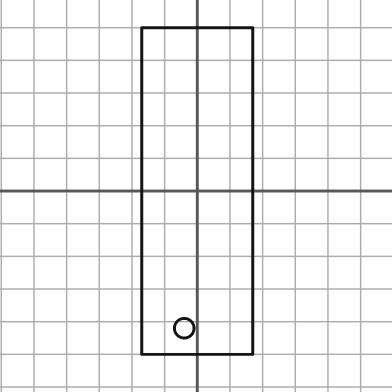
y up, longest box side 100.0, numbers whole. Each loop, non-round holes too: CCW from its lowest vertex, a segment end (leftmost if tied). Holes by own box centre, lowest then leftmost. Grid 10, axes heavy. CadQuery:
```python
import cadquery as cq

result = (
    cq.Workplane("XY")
    .moveTo(-17.0, -50.0)
    .lineTo(17.0, -50.0)
    .lineTo(17.0, 50.0)
    .lineTo(-17.0, 50.0)
    .close()
    .moveTo(-4.0, -42.0)
    .circle(3.0)
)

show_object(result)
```